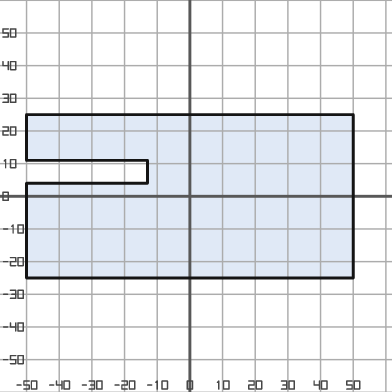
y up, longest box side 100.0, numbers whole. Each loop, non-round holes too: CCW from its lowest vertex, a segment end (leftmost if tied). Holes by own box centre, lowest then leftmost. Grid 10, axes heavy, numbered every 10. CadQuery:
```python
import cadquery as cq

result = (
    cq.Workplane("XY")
    .moveTo(-50.0, -25.0)
    .lineTo(50.0, -25.0)
    .lineTo(50.0, 25.0)
    .lineTo(-50.0, 25.0)
    .lineTo(-50.0, 11.0)
    .lineTo(-13.0, 11.0)
    .lineTo(-13.0, 4.0)
    .lineTo(-50.0, 4.0)
    .close()
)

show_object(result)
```